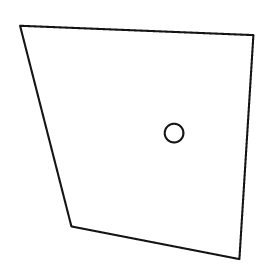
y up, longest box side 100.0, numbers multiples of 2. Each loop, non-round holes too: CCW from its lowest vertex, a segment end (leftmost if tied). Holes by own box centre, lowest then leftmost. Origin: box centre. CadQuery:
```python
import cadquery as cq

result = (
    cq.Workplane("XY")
    .moveTo(44.0, -50.0)
    .lineTo(50.0, 46.0)
    .lineTo(-50.0, 50.0)
    .lineTo(-28.0, -36.0)
    .close()
    .moveTo(16.0, 4.0)
    .circle(4.0)
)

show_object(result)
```